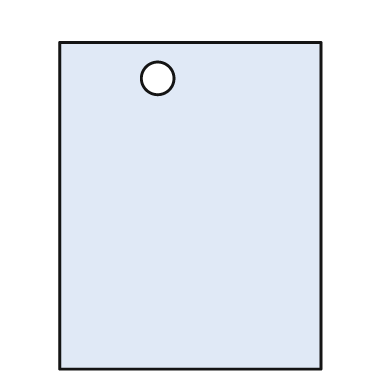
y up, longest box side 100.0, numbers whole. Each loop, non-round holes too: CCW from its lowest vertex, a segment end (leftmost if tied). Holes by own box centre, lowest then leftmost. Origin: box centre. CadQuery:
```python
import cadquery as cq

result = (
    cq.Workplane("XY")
    .moveTo(-40.0, -50.0)
    .lineTo(40.0, -50.0)
    .lineTo(40.0, 50.0)
    .lineTo(-40.0, 50.0)
    .close()
    .moveTo(-10.0, 39.0)
    .circle(5.0)
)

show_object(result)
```